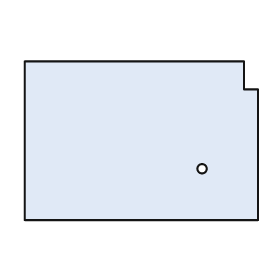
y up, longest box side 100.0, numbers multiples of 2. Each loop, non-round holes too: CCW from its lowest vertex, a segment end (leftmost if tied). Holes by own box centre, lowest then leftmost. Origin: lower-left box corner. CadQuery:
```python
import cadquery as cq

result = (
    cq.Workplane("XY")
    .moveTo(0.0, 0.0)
    .lineTo(100.0, 0.0)
    .lineTo(100.0, 56.0)
    .lineTo(94.0, 56.0)
    .lineTo(94.0, 68.0)
    .lineTo(0.0, 68.0)
    .close()
    .moveTo(76.0, 22.0)
    .circle(2.0)
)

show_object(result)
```